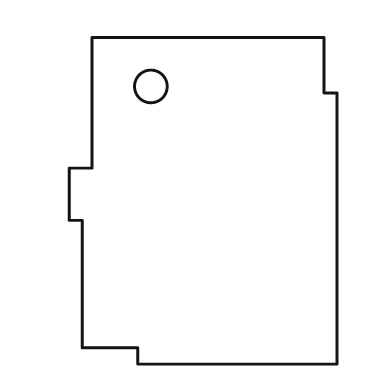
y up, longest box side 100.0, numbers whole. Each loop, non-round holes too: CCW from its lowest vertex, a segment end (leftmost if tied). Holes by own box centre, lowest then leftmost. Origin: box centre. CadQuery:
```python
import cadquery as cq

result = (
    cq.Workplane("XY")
    .moveTo(-20.0, -50.0)
    .lineTo(41.0, -50.0)
    .lineTo(41.0, 33.0)
    .lineTo(37.0, 33.0)
    .lineTo(37.0, 50.0)
    .lineTo(-34.0, 50.0)
    .lineTo(-34.0, 10.0)
    .lineTo(-41.0, 10.0)
    .lineTo(-41.0, -6.0)
    .lineTo(-37.0, -6.0)
    .lineTo(-37.0, -45.0)
    .lineTo(-20.0, -45.0)
    .close()
    .moveTo(-16.0, 35.0)
    .circle(5.0)
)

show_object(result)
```